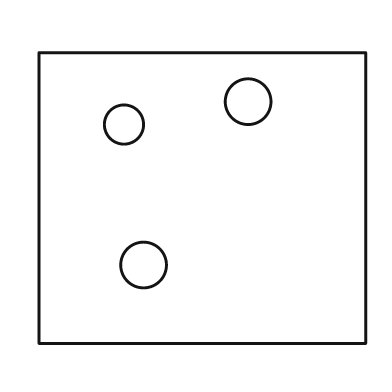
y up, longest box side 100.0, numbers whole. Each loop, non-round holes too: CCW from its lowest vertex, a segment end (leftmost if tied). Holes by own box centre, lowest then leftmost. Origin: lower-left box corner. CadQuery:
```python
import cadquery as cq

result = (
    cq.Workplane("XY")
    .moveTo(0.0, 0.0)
    .lineTo(100.0, 0.0)
    .lineTo(100.0, 89.0)
    .lineTo(0.0, 89.0)
    .close()
    .moveTo(32.0, 24.0)
    .circle(7.0)
    .moveTo(26.0, 67.0)
    .circle(6.0)
    .moveTo(64.0, 74.0)
    .circle(7.0)
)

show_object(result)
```